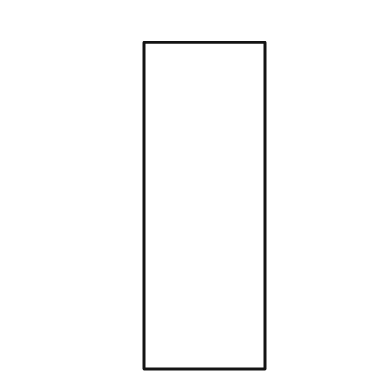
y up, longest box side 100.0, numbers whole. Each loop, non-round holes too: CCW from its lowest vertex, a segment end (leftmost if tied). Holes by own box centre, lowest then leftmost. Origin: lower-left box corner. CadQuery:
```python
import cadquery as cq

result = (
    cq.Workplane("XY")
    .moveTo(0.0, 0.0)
    .lineTo(37.0, 0.0)
    .lineTo(37.0, 100.0)
    .lineTo(0.0, 100.0)
    .close()
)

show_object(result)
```